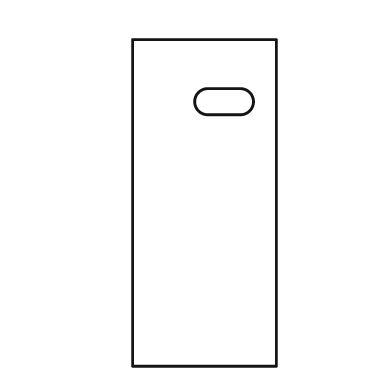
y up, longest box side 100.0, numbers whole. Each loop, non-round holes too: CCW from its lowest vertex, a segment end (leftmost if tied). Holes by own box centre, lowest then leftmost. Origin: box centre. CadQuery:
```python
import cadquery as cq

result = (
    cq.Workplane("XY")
    .moveTo(-22.0, -50.0)
    .lineTo(22.0, -50.0)
    .lineTo(22.0, 50.0)
    .lineTo(-22.0, 50.0)
    .close()
    .moveTo(1.0, 27.0)
    .lineTo(11.0, 27.0)
    .threePointArc((15.0, 31.0), (11.0, 35.0))
    .lineTo(1.0, 35.0)
    .threePointArc((-3.0, 31.0), (1.0, 27.0))
    .close()
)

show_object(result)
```